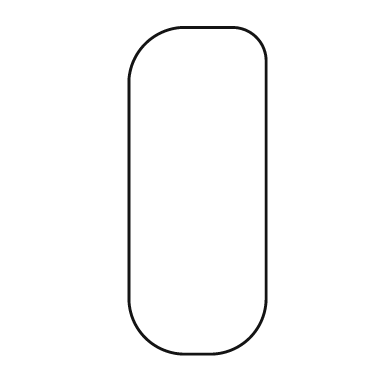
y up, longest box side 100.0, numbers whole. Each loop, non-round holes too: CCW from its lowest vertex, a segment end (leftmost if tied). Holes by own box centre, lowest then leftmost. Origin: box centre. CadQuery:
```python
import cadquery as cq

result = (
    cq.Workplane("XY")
    .moveTo(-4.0, -50.0)
    .lineTo(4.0, -50.0)
    .threePointArc((16.0, -45.0), (21.0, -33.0))
    .lineTo(21.0, 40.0)
    .threePointArc((18.0, 47.0), (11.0, 50.0))
    .lineTo(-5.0, 50.0)
    .threePointArc((-16.0, 45.0), (-21.0, 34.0))
    .lineTo(-21.0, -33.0)
    .threePointArc((-16.0, -45.0), (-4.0, -50.0))
    .close()
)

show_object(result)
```